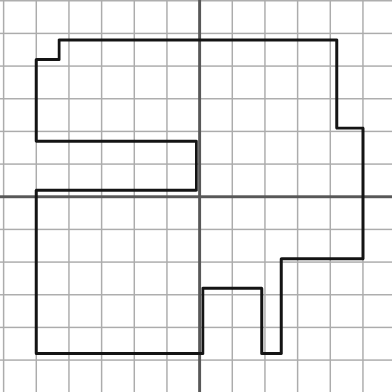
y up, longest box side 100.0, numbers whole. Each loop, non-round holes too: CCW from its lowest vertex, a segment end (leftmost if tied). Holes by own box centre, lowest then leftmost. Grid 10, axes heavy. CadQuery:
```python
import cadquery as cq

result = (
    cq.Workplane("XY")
    .moveTo(-50.0, -48.0)
    .lineTo(1.0, -48.0)
    .lineTo(1.0, -28.0)
    .lineTo(19.0, -28.0)
    .lineTo(19.0, -48.0)
    .lineTo(25.0, -48.0)
    .lineTo(25.0, -19.0)
    .lineTo(50.0, -19.0)
    .lineTo(50.0, 21.0)
    .lineTo(42.0, 21.0)
    .lineTo(42.0, 48.0)
    .lineTo(-43.0, 48.0)
    .lineTo(-43.0, 42.0)
    .lineTo(-50.0, 42.0)
    .lineTo(-50.0, 17.0)
    .lineTo(-1.0, 17.0)
    .lineTo(-1.0, 2.0)
    .lineTo(-50.0, 2.0)
    .close()
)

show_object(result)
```